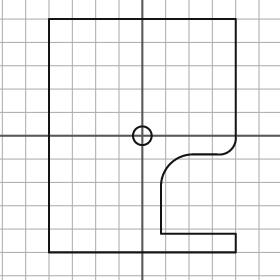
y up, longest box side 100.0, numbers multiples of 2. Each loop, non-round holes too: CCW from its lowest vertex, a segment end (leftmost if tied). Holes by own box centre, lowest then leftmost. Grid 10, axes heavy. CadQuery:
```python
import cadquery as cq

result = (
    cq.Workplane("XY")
    .moveTo(-40.0, -50.0)
    .lineTo(40.0, -50.0)
    .lineTo(40.0, -42.0)
    .lineTo(8.0, -42.0)
    .lineTo(8.0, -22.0)
    .threePointArc((12.0, -12.0), (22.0, -8.0))
    .lineTo(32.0, -8.0)
    .threePointArc((38.0, -6.0), (40.0, 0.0))
    .lineTo(40.0, 50.0)
    .lineTo(-40.0, 50.0)
    .close()
    .moveTo(0.0, 0.0)
    .circle(4.0)
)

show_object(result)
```